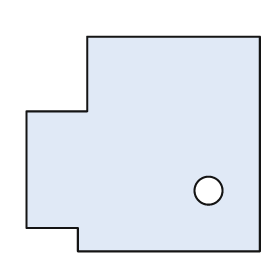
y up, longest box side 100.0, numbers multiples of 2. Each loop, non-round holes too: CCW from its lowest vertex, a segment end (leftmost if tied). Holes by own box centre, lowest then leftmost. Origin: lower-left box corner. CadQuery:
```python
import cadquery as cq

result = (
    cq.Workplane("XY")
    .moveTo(22.0, 0.0)
    .lineTo(100.0, 0.0)
    .lineTo(100.0, 92.0)
    .lineTo(26.0, 92.0)
    .lineTo(26.0, 60.0)
    .lineTo(0.0, 60.0)
    .lineTo(0.0, 10.0)
    .lineTo(22.0, 10.0)
    .close()
    .moveTo(78.0, 26.0)
    .circle(6.0)
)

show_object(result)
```